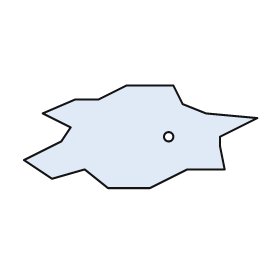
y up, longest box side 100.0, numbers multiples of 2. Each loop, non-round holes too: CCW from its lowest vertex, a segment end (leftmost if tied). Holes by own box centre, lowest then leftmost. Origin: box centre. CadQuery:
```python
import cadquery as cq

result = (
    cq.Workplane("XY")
    .moveTo(-14.0, -22.0)
    .lineTo(4.0, -22.0)
    .lineTo(20.0, -14.0)
    .lineTo(36.0, -14.0)
    .lineTo(34.0, -4.0)
    .lineTo(34.0, 0.0)
    .lineTo(50.0, 8.0)
    .lineTo(28.0, 10.0)
    .lineTo(18.0, 14.0)
    .lineTo(14.0, 22.0)
    .lineTo(-6.0, 22.0)
    .lineTo(-18.0, 16.0)
    .lineTo(-28.0, 16.0)
    .lineTo(-42.0, 10.0)
    .lineTo(-30.0, 4.0)
    .lineTo(-34.0, -2.0)
    .lineTo(-50.0, -10.0)
    .lineTo(-38.0, -18.0)
    .lineTo(-24.0, -14.0)
    .close()
    .moveTo(12.0, 0.0)
    .circle(2.0)
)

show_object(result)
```